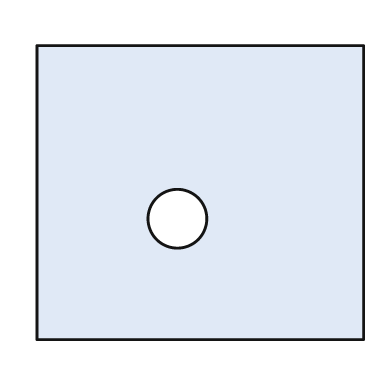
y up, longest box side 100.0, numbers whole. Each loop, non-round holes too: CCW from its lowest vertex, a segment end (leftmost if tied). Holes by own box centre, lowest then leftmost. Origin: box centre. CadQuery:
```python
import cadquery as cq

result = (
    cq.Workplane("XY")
    .moveTo(-50.0, -45.0)
    .lineTo(50.0, -45.0)
    .lineTo(50.0, 45.0)
    .lineTo(-50.0, 45.0)
    .close()
    .moveTo(-7.0, -8.0)
    .circle(9.0)
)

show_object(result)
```